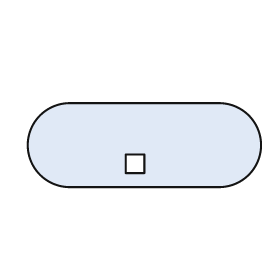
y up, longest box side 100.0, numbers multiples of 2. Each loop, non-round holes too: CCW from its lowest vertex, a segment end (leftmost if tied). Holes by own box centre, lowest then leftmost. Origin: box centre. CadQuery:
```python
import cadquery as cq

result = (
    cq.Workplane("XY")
    .moveTo(-32.0, -18.0)
    .lineTo(32.0, -18.0)
    .threePointArc((50.0, 0.0), (32.0, 18.0))
    .lineTo(-32.0, 18.0)
    .threePointArc((-50.0, 0.0), (-32.0, -18.0))
    .close()
    .moveTo(-8.0, -12.0)
    .lineTo(0.0, -12.0)
    .lineTo(0.0, -4.0)
    .lineTo(-8.0, -4.0)
    .close()
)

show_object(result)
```